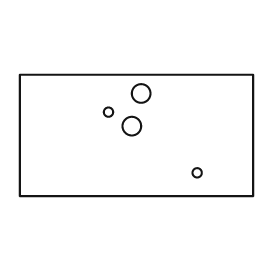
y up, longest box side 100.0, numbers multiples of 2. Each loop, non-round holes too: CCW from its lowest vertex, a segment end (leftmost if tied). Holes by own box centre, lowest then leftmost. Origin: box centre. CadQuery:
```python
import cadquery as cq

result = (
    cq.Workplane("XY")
    .moveTo(-50.0, -26.0)
    .lineTo(50.0, -26.0)
    .lineTo(50.0, 26.0)
    .lineTo(-50.0, 26.0)
    .close()
    .moveTo(26.0, -16.0)
    .circle(2.0)
    .moveTo(-2.0, 4.0)
    .circle(4.0)
    .moveTo(-12.0, 10.0)
    .circle(2.0)
    .moveTo(2.0, 18.0)
    .circle(4.0)
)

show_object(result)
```